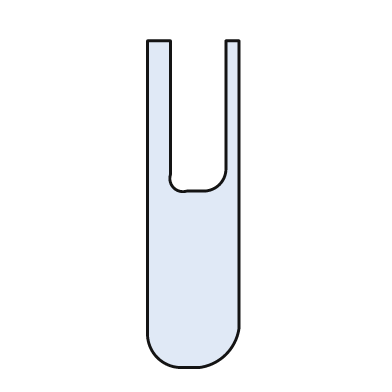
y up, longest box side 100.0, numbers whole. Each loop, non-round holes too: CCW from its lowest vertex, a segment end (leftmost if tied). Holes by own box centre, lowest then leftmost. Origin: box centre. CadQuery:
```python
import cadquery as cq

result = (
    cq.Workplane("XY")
    .moveTo(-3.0, -50.0)
    .lineTo(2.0, -50.0)
    .threePointArc((10.0, -46.0), (14.0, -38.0))
    .lineTo(14.0, 50.0)
    .lineTo(10.0, 50.0)
    .lineTo(10.0, 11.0)
    .threePointArc((8.0, 6.0), (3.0, 4.0))
    .lineTo(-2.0, 4.0)
    .threePointArc((-6.0, 5.0), (-7.0, 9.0))
    .lineTo(-7.0, 50.0)
    .lineTo(-14.0, 50.0)
    .lineTo(-14.0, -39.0)
    .threePointArc((-11.0, -47.0), (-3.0, -50.0))
    .close()
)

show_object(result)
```